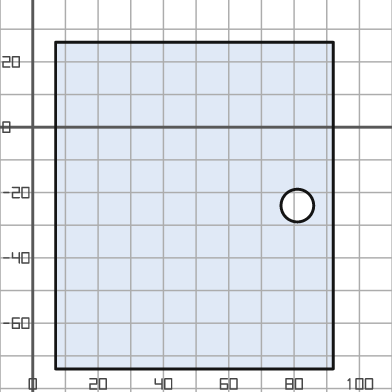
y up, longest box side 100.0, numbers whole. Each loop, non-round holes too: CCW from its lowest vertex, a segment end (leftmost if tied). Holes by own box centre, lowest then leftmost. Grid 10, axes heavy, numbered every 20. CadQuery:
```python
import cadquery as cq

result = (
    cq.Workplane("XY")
    .moveTo(7.0, -74.0)
    .lineTo(92.0, -74.0)
    .lineTo(92.0, 26.0)
    .lineTo(7.0, 26.0)
    .close()
    .moveTo(81.0, -24.0)
    .circle(5.0)
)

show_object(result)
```